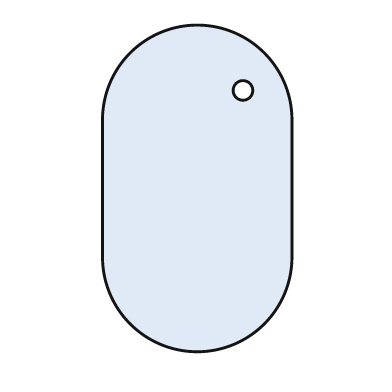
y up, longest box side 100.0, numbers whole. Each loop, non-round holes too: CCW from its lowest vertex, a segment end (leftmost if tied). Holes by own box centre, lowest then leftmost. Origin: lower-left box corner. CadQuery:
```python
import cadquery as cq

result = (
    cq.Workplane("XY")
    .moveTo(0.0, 29.0)
    .threePointArc((29.0, 0.0), (58.0, 29.0))
    .lineTo(58.0, 71.0)
    .threePointArc((29.0, 100.0), (0.0, 71.0))
    .close()
    .moveTo(43.0, 80.0)
    .circle(3.0)
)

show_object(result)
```